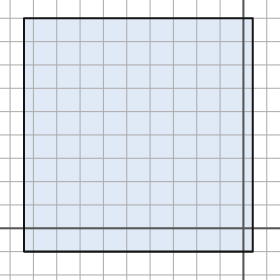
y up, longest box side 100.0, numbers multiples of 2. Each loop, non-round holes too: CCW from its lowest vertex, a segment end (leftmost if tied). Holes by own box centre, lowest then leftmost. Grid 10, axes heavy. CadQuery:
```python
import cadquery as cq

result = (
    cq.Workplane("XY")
    .moveTo(-94.0, -10.0)
    .lineTo(4.0, -10.0)
    .lineTo(4.0, 90.0)
    .lineTo(-94.0, 90.0)
    .close()
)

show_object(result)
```